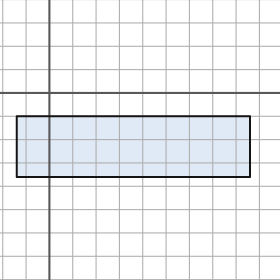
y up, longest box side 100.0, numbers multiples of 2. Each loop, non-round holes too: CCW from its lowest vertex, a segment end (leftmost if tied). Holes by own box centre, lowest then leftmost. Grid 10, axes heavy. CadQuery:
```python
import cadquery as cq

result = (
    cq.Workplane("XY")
    .moveTo(-14.0, -36.0)
    .lineTo(86.0, -36.0)
    .lineTo(86.0, -10.0)
    .lineTo(-14.0, -10.0)
    .close()
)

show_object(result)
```